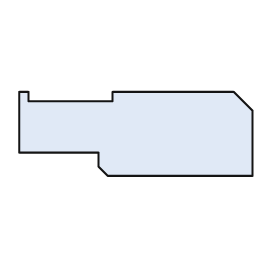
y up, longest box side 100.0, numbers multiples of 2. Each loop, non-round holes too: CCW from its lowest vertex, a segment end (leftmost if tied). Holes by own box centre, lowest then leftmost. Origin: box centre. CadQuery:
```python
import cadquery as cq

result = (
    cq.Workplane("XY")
    .moveTo(-12.0, -18.0)
    .lineTo(50.0, -18.0)
    .lineTo(50.0, 10.0)
    .lineTo(42.0, 18.0)
    .lineTo(-10.0, 18.0)
    .lineTo(-10.0, 14.0)
    .lineTo(-46.0, 14.0)
    .lineTo(-46.0, 18.0)
    .lineTo(-50.0, 18.0)
    .lineTo(-50.0, -8.0)
    .lineTo(-16.0, -8.0)
    .lineTo(-16.0, -14.0)
    .close()
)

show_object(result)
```